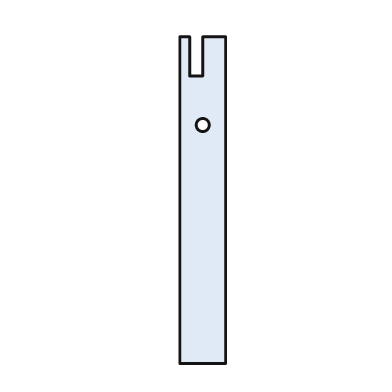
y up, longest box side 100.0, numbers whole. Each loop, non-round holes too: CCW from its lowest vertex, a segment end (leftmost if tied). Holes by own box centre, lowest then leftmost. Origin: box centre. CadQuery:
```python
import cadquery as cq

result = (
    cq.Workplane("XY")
    .moveTo(-7.0, -50.0)
    .lineTo(7.0, -50.0)
    .lineTo(7.0, 50.0)
    .lineTo(0.0, 50.0)
    .lineTo(0.0, 38.0)
    .lineTo(-4.0, 38.0)
    .lineTo(-4.0, 50.0)
    .lineTo(-7.0, 50.0)
    .close()
    .moveTo(0.0, 23.0)
    .circle(2.0)
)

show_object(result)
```